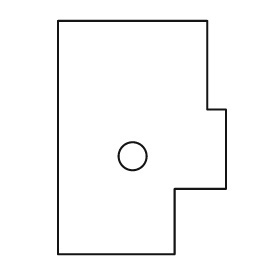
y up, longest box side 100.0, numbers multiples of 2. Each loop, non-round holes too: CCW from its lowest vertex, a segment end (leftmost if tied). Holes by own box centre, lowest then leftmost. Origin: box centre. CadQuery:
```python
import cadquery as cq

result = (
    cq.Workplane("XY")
    .moveTo(-36.0, -50.0)
    .lineTo(14.0, -50.0)
    .lineTo(14.0, -22.0)
    .lineTo(36.0, -22.0)
    .lineTo(36.0, 12.0)
    .lineTo(28.0, 12.0)
    .lineTo(28.0, 50.0)
    .lineTo(-36.0, 50.0)
    .close()
    .moveTo(-4.0, -8.0)
    .circle(6.0)
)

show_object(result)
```